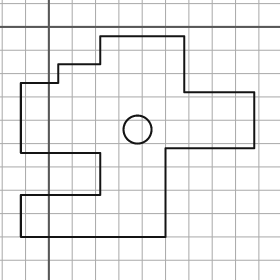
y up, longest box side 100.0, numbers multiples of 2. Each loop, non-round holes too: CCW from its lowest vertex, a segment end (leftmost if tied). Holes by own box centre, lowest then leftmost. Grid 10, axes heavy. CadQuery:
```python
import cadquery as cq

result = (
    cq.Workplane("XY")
    .moveTo(-12.0, -90.0)
    .lineTo(50.0, -90.0)
    .lineTo(50.0, -52.0)
    .lineTo(88.0, -52.0)
    .lineTo(88.0, -28.0)
    .lineTo(58.0, -28.0)
    .lineTo(58.0, -4.0)
    .lineTo(22.0, -4.0)
    .lineTo(22.0, -16.0)
    .lineTo(4.0, -16.0)
    .lineTo(4.0, -24.0)
    .lineTo(-12.0, -24.0)
    .lineTo(-12.0, -54.0)
    .lineTo(22.0, -54.0)
    .lineTo(22.0, -72.0)
    .lineTo(-12.0, -72.0)
    .close()
    .moveTo(38.0, -44.0)
    .circle(6.0)
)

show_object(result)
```